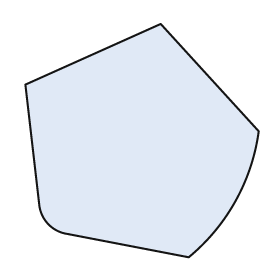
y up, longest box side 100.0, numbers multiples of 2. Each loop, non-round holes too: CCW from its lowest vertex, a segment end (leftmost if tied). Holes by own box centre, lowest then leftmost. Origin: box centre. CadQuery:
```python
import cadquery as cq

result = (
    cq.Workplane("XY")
    .moveTo(20.0, -50.0)
    .threePointArc((40.0, -26.0), (50.0, 4.0))
    .lineTo(8.0, 50.0)
    .lineTo(-50.0, 24.0)
    .lineTo(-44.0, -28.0)
    .threePointArc((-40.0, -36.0), (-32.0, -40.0))
    .close()
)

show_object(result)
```